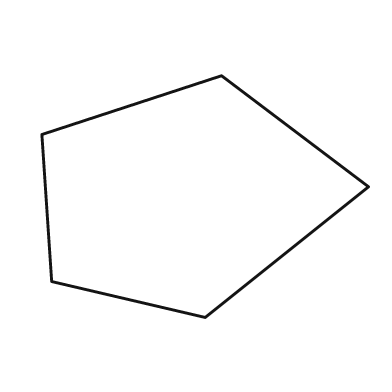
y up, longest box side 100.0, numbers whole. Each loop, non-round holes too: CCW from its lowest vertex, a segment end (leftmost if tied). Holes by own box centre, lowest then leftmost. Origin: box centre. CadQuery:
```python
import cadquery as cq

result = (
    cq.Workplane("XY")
    .moveTo(0.0, -37.0)
    .lineTo(50.0, 3.0)
    .lineTo(5.0, 37.0)
    .lineTo(-50.0, 19.0)
    .lineTo(-47.0, -26.0)
    .close()
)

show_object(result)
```